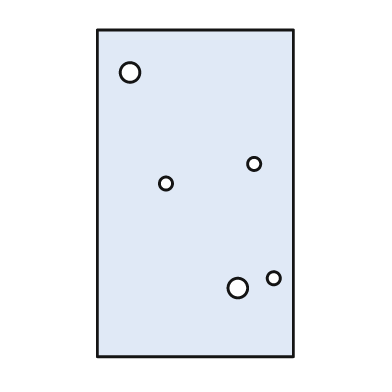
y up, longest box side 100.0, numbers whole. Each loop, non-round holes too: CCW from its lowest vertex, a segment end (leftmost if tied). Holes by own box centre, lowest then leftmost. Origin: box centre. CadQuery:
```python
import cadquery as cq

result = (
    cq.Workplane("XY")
    .moveTo(-30.0, -50.0)
    .lineTo(30.0, -50.0)
    .lineTo(30.0, 50.0)
    .lineTo(-30.0, 50.0)
    .close()
    .moveTo(13.0, -29.0)
    .circle(3.0)
    .moveTo(24.0, -26.0)
    .circle(2.0)
    .moveTo(-9.0, 3.0)
    .circle(2.0)
    .moveTo(18.0, 9.0)
    .circle(2.0)
    .moveTo(-20.0, 37.0)
    .circle(3.0)
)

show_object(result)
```